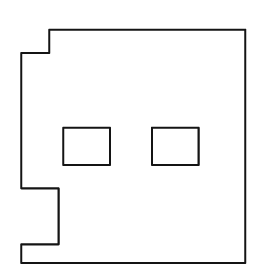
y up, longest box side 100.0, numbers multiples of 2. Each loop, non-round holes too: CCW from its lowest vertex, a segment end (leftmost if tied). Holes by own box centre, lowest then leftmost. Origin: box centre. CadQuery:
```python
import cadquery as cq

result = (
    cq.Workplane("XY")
    .moveTo(-48.0, -50.0)
    .lineTo(48.0, -50.0)
    .lineTo(48.0, 50.0)
    .lineTo(-36.0, 50.0)
    .lineTo(-36.0, 40.0)
    .lineTo(-48.0, 40.0)
    .lineTo(-48.0, -18.0)
    .lineTo(-32.0, -18.0)
    .lineTo(-32.0, -42.0)
    .lineTo(-48.0, -42.0)
    .close()
    .moveTo(-30.0, -8.0)
    .lineTo(-10.0, -8.0)
    .lineTo(-10.0, 8.0)
    .lineTo(-30.0, 8.0)
    .close()
    .moveTo(8.0, -8.0)
    .lineTo(28.0, -8.0)
    .lineTo(28.0, 8.0)
    .lineTo(8.0, 8.0)
    .close()
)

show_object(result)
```